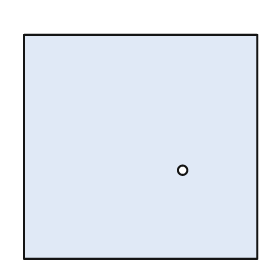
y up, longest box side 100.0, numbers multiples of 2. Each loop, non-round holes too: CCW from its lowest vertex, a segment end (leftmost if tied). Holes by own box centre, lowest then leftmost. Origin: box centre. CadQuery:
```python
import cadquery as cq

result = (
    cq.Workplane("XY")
    .moveTo(-50.0, -48.0)
    .lineTo(50.0, -48.0)
    .lineTo(50.0, 48.0)
    .lineTo(-50.0, 48.0)
    .close()
    .moveTo(18.0, -10.0)
    .circle(2.0)
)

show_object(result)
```